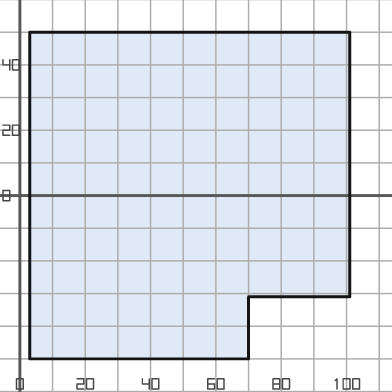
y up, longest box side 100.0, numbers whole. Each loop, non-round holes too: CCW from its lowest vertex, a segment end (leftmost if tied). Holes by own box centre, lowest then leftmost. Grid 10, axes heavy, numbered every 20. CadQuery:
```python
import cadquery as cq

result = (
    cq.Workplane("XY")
    .moveTo(3.0, -50.0)
    .lineTo(70.0, -50.0)
    .lineTo(70.0, -31.0)
    .lineTo(101.0, -31.0)
    .lineTo(101.0, 50.0)
    .lineTo(3.0, 50.0)
    .close()
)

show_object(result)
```